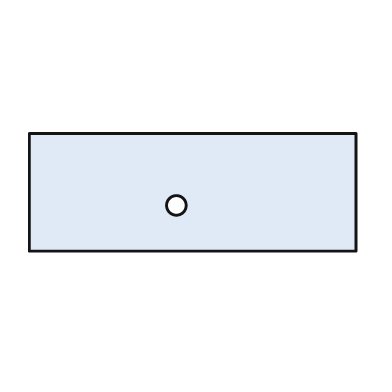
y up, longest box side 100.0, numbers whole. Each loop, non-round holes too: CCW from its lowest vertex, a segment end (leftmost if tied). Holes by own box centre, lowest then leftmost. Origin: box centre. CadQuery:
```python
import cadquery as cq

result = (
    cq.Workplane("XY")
    .moveTo(-50.0, -18.0)
    .lineTo(50.0, -18.0)
    .lineTo(50.0, 18.0)
    .lineTo(-50.0, 18.0)
    .close()
    .moveTo(-5.0, -4.0)
    .circle(3.0)
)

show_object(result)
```